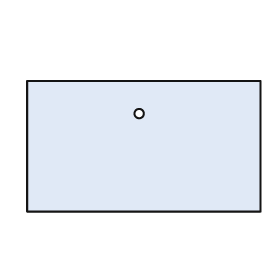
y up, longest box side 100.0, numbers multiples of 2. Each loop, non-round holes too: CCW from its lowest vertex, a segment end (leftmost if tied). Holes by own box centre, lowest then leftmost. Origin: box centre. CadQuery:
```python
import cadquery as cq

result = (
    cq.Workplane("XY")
    .moveTo(-50.0, -28.0)
    .lineTo(50.0, -28.0)
    .lineTo(50.0, 28.0)
    .lineTo(-50.0, 28.0)
    .close()
    .moveTo(-2.0, 14.0)
    .circle(2.0)
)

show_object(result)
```